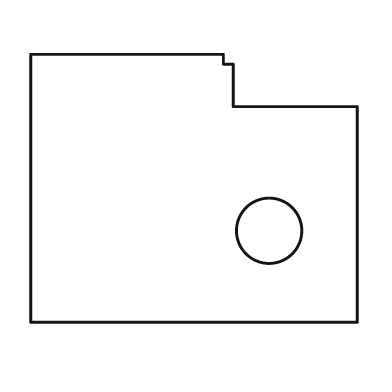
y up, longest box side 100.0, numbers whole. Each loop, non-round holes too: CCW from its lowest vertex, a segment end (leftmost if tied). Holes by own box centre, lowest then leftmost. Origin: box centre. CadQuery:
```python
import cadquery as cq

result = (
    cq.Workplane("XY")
    .moveTo(-50.0, -41.0)
    .lineTo(50.0, -41.0)
    .lineTo(50.0, 25.0)
    .lineTo(12.0, 25.0)
    .lineTo(12.0, 38.0)
    .lineTo(9.0, 38.0)
    .lineTo(9.0, 41.0)
    .lineTo(-50.0, 41.0)
    .close()
    .moveTo(23.0, -13.0)
    .circle(10.0)
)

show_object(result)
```